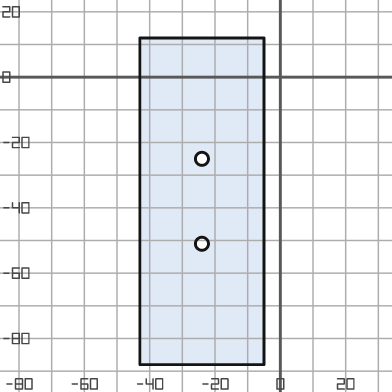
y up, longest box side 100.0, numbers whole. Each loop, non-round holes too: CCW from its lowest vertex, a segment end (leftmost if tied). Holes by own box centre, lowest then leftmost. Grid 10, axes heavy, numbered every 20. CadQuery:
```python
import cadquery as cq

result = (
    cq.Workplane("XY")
    .moveTo(-43.0, -88.0)
    .lineTo(-5.0, -88.0)
    .lineTo(-5.0, 12.0)
    .lineTo(-43.0, 12.0)
    .close()
    .moveTo(-24.0, -51.0)
    .circle(2.0)
    .moveTo(-24.0, -25.0)
    .circle(2.0)
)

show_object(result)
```